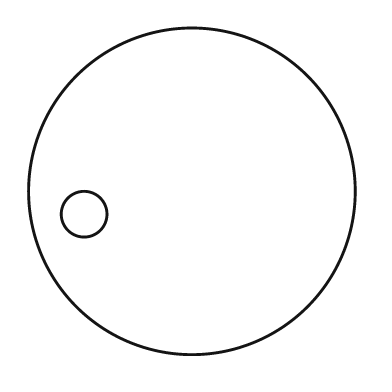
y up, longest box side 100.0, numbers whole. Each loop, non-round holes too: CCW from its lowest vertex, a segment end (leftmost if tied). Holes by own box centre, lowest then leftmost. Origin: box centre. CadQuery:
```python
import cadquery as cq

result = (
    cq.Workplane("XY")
    .moveTo(0.0, 0.0)
    .circle(50.0)
    .moveTo(-33.0, -7.0)
    .circle(7.0)
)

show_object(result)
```